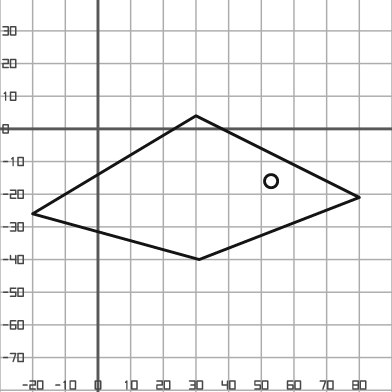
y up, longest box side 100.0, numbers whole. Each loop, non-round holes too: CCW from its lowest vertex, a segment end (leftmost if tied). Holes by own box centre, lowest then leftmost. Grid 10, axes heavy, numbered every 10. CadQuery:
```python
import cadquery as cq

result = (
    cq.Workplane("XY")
    .moveTo(31.0, -40.0)
    .lineTo(80.0, -21.0)
    .lineTo(30.0, 4.0)
    .lineTo(-20.0, -26.0)
    .close()
    .moveTo(53.0, -16.0)
    .circle(2.0)
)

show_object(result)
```